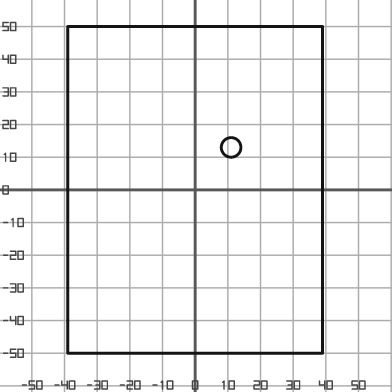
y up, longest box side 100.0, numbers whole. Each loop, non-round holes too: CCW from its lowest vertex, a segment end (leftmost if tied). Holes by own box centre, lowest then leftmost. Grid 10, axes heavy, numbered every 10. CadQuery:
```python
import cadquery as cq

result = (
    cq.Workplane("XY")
    .moveTo(-39.0, -50.0)
    .lineTo(39.0, -50.0)
    .lineTo(39.0, 50.0)
    .lineTo(-39.0, 50.0)
    .close()
    .moveTo(11.0, 13.0)
    .circle(3.0)
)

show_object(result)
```